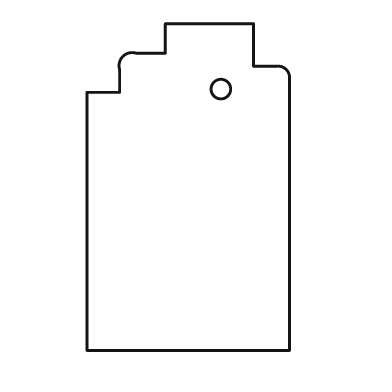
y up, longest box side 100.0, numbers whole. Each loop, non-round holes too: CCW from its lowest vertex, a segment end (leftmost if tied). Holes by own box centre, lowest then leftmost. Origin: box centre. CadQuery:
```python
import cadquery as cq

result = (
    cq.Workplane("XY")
    .moveTo(-31.0, -50.0)
    .lineTo(31.0, -50.0)
    .lineTo(31.0, 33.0)
    .threePointArc((30.0, 36.0), (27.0, 37.0))
    .lineTo(20.0, 37.0)
    .lineTo(20.0, 50.0)
    .lineTo(-7.0, 50.0)
    .lineTo(-7.0, 41.0)
    .lineTo(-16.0, 41.0)
    .threePointArc((-20.0, 40.0), (-21.0, 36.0))
    .lineTo(-21.0, 29.0)
    .lineTo(-31.0, 29.0)
    .close()
    .moveTo(10.0, 30.0)
    .circle(3.0)
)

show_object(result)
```